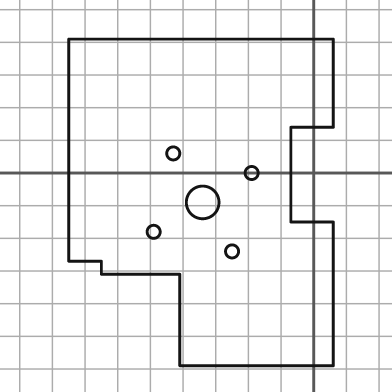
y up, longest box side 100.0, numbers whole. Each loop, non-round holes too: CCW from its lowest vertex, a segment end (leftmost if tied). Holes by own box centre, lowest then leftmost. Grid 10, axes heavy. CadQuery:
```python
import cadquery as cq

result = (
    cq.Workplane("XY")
    .moveTo(-41.0, -59.0)
    .lineTo(6.0, -59.0)
    .lineTo(6.0, -15.0)
    .lineTo(-7.0, -15.0)
    .lineTo(-7.0, 14.0)
    .lineTo(6.0, 14.0)
    .lineTo(6.0, 41.0)
    .lineTo(-75.0, 41.0)
    .lineTo(-75.0, -27.0)
    .lineTo(-65.0, -27.0)
    .lineTo(-65.0, -31.0)
    .lineTo(-41.0, -31.0)
    .close()
    .moveTo(-25.0, -24.0)
    .circle(2.0)
    .moveTo(-49.0, -18.0)
    .circle(2.0)
    .moveTo(-34.0, -9.0)
    .circle(5.0)
    .moveTo(-19.0, 0.0)
    .circle(2.0)
    .moveTo(-43.0, 6.0)
    .circle(2.0)
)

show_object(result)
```